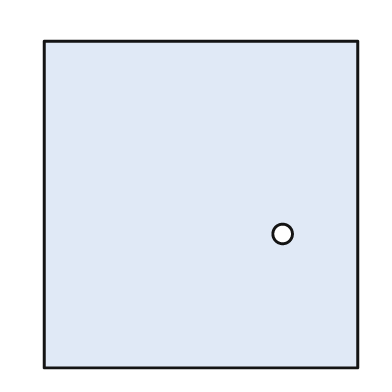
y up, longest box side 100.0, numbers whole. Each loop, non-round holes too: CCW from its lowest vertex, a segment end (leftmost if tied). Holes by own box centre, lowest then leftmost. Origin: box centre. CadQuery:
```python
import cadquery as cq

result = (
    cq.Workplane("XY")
    .moveTo(-48.0, -50.0)
    .lineTo(48.0, -50.0)
    .lineTo(48.0, 50.0)
    .lineTo(-48.0, 50.0)
    .close()
    .moveTo(25.0, -9.0)
    .circle(3.0)
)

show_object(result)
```